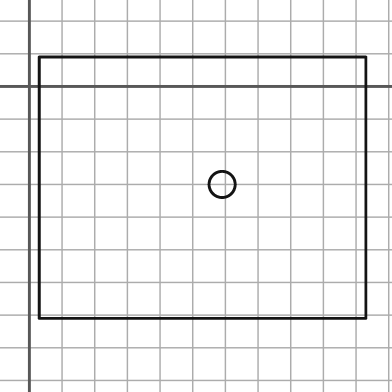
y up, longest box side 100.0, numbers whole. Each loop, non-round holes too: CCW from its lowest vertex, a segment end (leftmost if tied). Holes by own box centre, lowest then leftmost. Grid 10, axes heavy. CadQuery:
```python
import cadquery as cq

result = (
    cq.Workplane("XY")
    .moveTo(3.0, -71.0)
    .lineTo(103.0, -71.0)
    .lineTo(103.0, 9.0)
    .lineTo(3.0, 9.0)
    .close()
    .moveTo(59.0, -30.0)
    .circle(4.0)
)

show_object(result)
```